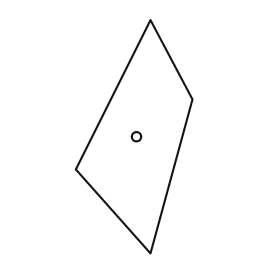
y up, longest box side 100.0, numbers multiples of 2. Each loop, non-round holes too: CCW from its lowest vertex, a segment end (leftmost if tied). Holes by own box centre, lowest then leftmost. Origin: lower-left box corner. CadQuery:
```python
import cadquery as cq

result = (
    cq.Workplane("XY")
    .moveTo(32.0, 0.0)
    .lineTo(50.0, 66.0)
    .lineTo(32.0, 100.0)
    .lineTo(0.0, 36.0)
    .close()
    .moveTo(26.0, 50.0)
    .circle(2.0)
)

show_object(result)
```